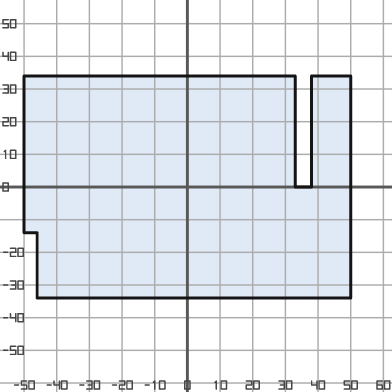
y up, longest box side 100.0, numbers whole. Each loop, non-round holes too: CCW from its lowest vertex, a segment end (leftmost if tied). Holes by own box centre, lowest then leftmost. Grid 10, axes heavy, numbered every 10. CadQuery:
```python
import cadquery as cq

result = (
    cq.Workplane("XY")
    .moveTo(-46.0, -34.0)
    .lineTo(50.0, -34.0)
    .lineTo(50.0, 34.0)
    .lineTo(38.0, 34.0)
    .lineTo(38.0, 0.0)
    .lineTo(33.0, 0.0)
    .lineTo(33.0, 34.0)
    .lineTo(-50.0, 34.0)
    .lineTo(-50.0, -14.0)
    .lineTo(-46.0, -14.0)
    .close()
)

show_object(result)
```